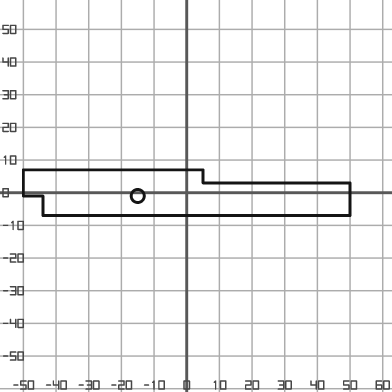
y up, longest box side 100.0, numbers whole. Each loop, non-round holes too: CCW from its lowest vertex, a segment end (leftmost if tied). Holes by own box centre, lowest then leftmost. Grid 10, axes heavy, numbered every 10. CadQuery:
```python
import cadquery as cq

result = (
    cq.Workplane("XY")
    .moveTo(-44.0, -7.0)
    .lineTo(50.0, -7.0)
    .lineTo(50.0, 3.0)
    .lineTo(5.0, 3.0)
    .lineTo(5.0, 7.0)
    .lineTo(-50.0, 7.0)
    .lineTo(-50.0, -1.0)
    .lineTo(-44.0, -1.0)
    .close()
    .moveTo(-15.0, -1.0)
    .circle(2.0)
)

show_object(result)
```